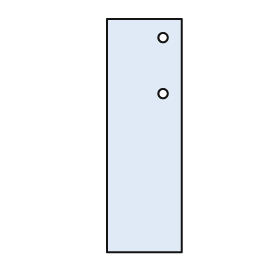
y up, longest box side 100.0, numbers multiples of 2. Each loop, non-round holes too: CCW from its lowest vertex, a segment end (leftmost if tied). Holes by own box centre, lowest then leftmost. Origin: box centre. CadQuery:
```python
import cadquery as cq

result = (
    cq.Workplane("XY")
    .moveTo(-16.0, -50.0)
    .lineTo(16.0, -50.0)
    .lineTo(16.0, 50.0)
    .lineTo(-16.0, 50.0)
    .close()
    .moveTo(8.0, 18.0)
    .circle(2.0)
    .moveTo(8.0, 42.0)
    .circle(2.0)
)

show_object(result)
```